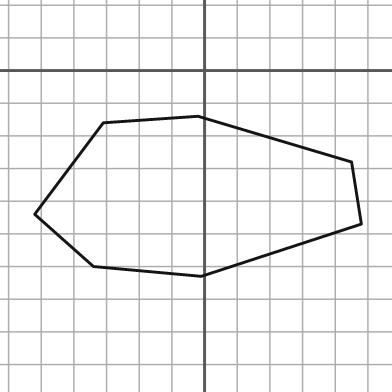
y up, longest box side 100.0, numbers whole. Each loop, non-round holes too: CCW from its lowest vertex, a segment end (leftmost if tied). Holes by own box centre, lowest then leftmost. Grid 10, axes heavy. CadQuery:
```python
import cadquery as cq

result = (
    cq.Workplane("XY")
    .moveTo(-1.0, -63.0)
    .lineTo(48.0, -47.0)
    .lineTo(45.0, -28.0)
    .lineTo(-2.0, -14.0)
    .lineTo(-31.0, -16.0)
    .lineTo(-52.0, -44.0)
    .lineTo(-34.0, -60.0)
    .close()
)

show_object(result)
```